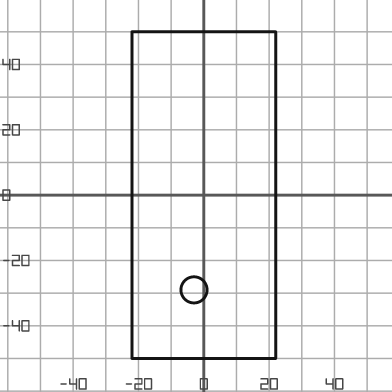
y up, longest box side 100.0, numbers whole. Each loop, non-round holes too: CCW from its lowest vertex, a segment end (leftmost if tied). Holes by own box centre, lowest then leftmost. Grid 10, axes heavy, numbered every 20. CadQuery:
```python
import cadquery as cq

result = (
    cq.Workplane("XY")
    .moveTo(-22.0, -50.0)
    .lineTo(22.0, -50.0)
    .lineTo(22.0, 50.0)
    .lineTo(-22.0, 50.0)
    .close()
    .moveTo(-3.0, -29.0)
    .circle(4.0)
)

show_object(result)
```